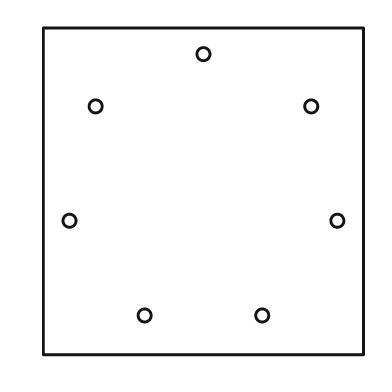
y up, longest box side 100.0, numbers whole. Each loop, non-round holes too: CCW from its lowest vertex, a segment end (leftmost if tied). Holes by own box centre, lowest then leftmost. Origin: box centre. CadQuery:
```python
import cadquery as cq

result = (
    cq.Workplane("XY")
    .moveTo(-49.0, -50.0)
    .lineTo(49.0, -50.0)
    .lineTo(49.0, 50.0)
    .lineTo(-49.0, 50.0)
    .close()
    .moveTo(-18.0, -38.0)
    .circle(2.0)
    .moveTo(18.0, -38.0)
    .circle(2.0)
    .moveTo(-41.0, -9.0)
    .circle(2.0)
    .moveTo(41.0, -9.0)
    .circle(2.0)
    .moveTo(-33.0, 26.0)
    .circle(2.0)
    .moveTo(33.0, 26.0)
    .circle(2.0)
    .moveTo(0.0, 42.0)
    .circle(2.0)
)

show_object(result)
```